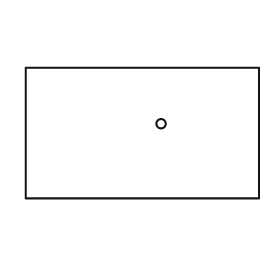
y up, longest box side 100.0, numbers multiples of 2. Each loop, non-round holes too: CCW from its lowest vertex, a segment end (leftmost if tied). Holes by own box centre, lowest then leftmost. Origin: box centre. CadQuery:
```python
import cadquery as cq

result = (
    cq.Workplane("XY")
    .moveTo(-50.0, -28.0)
    .lineTo(50.0, -28.0)
    .lineTo(50.0, 28.0)
    .lineTo(-50.0, 28.0)
    .close()
    .moveTo(8.0, 4.0)
    .circle(2.0)
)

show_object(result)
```